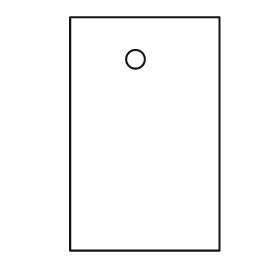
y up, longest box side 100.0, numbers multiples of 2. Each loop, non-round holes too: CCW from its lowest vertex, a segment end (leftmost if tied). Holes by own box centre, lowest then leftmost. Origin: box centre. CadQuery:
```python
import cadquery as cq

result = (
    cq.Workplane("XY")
    .moveTo(-32.0, -50.0)
    .lineTo(32.0, -50.0)
    .lineTo(32.0, 50.0)
    .lineTo(-32.0, 50.0)
    .close()
    .moveTo(-4.0, 32.0)
    .circle(4.0)
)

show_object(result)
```